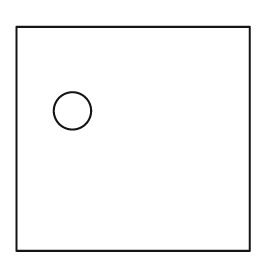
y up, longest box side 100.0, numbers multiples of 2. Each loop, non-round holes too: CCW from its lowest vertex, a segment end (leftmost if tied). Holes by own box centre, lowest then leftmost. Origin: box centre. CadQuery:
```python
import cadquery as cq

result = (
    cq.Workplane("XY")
    .moveTo(-50.0, -48.0)
    .lineTo(50.0, -48.0)
    .lineTo(50.0, 48.0)
    .lineTo(-50.0, 48.0)
    .close()
    .moveTo(-26.0, 12.0)
    .circle(8.0)
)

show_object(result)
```